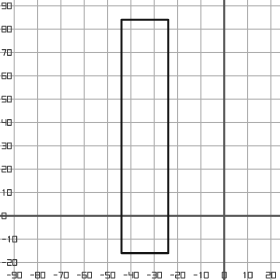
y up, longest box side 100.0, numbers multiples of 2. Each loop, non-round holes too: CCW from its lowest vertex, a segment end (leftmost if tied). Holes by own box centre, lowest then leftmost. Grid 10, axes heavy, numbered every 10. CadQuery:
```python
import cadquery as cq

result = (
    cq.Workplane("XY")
    .moveTo(-44.0, -16.0)
    .lineTo(-24.0, -16.0)
    .lineTo(-24.0, 84.0)
    .lineTo(-44.0, 84.0)
    .close()
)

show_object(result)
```